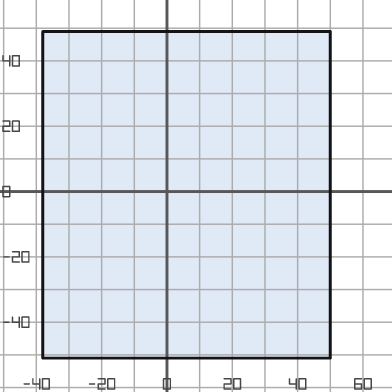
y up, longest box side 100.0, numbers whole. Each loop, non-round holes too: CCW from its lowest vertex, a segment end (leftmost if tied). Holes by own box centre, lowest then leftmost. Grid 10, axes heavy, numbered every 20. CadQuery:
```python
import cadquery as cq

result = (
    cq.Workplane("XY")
    .moveTo(-38.0, -51.0)
    .lineTo(50.0, -51.0)
    .lineTo(50.0, 49.0)
    .lineTo(-38.0, 49.0)
    .close()
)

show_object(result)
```